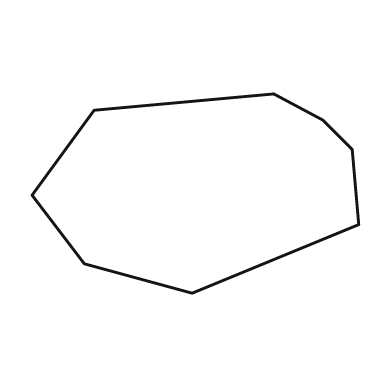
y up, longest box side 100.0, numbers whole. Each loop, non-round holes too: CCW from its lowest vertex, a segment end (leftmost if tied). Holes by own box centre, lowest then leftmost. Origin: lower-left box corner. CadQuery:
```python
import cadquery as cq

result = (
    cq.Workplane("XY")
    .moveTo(49.0, 0.0)
    .lineTo(100.0, 21.0)
    .lineTo(98.0, 44.0)
    .lineTo(89.0, 53.0)
    .lineTo(74.0, 61.0)
    .lineTo(19.0, 56.0)
    .lineTo(0.0, 30.0)
    .lineTo(16.0, 9.0)
    .close()
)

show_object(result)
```